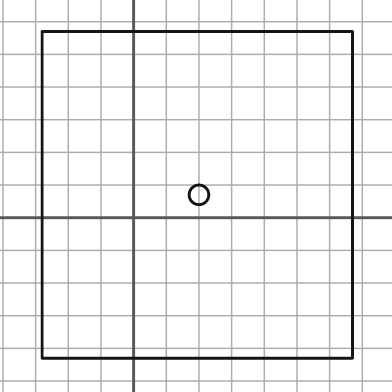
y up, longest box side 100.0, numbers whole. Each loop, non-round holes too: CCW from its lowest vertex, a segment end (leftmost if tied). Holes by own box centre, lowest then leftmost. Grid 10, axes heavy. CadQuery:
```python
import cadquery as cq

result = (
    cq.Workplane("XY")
    .moveTo(-28.0, -43.0)
    .lineTo(67.0, -43.0)
    .lineTo(67.0, 57.0)
    .lineTo(-28.0, 57.0)
    .close()
    .moveTo(20.0, 7.0)
    .circle(3.0)
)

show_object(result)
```